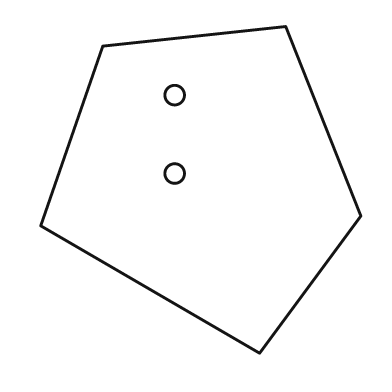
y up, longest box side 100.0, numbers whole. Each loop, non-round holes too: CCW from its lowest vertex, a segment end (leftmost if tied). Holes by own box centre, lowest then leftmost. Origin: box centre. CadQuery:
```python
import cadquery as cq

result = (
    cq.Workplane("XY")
    .moveTo(18.0, -50.0)
    .lineTo(49.0, -8.0)
    .lineTo(26.0, 50.0)
    .lineTo(-30.0, 44.0)
    .lineTo(-49.0, -11.0)
    .close()
    .moveTo(-8.0, 5.0)
    .circle(3.0)
    .moveTo(-8.0, 29.0)
    .circle(3.0)
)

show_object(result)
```